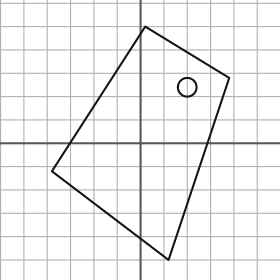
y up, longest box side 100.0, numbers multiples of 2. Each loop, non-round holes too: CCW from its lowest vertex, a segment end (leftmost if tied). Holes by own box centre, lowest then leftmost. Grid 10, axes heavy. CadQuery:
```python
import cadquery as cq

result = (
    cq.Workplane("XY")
    .moveTo(12.0, -50.0)
    .lineTo(38.0, 28.0)
    .lineTo(2.0, 50.0)
    .lineTo(-38.0, -12.0)
    .close()
    .moveTo(20.0, 24.0)
    .circle(4.0)
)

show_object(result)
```